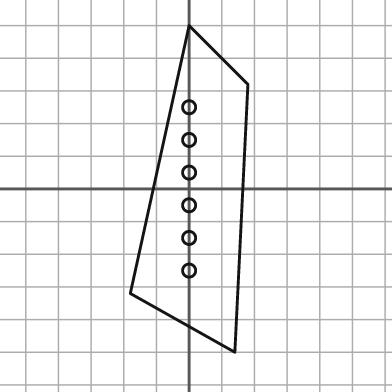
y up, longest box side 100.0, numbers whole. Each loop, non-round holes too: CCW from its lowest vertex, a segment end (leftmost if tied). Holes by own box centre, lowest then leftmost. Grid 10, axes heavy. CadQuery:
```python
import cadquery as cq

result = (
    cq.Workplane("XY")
    .moveTo(14.0, -50.0)
    .lineTo(18.0, 32.0)
    .lineTo(0.0, 50.0)
    .lineTo(-18.0, -32.0)
    .close()
    .moveTo(0.0, -25.0)
    .circle(2.0)
    .moveTo(0.0, -15.0)
    .circle(2.0)
    .moveTo(0.0, -5.0)
    .circle(2.0)
    .moveTo(0.0, 5.0)
    .circle(2.0)
    .moveTo(0.0, 15.0)
    .circle(2.0)
    .moveTo(0.0, 25.0)
    .circle(2.0)
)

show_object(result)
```